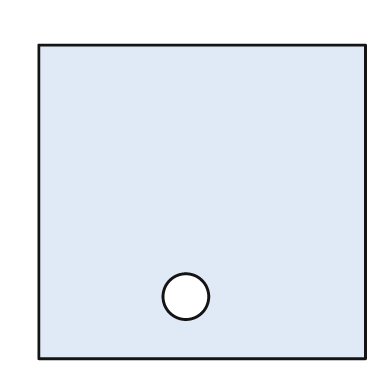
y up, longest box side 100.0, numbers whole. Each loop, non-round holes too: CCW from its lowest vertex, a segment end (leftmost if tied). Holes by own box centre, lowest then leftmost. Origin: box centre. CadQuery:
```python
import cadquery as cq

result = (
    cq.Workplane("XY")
    .moveTo(-50.0, -48.0)
    .lineTo(50.0, -48.0)
    .lineTo(50.0, 48.0)
    .lineTo(-50.0, 48.0)
    .close()
    .moveTo(-5.0, -29.0)
    .circle(7.0)
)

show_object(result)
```